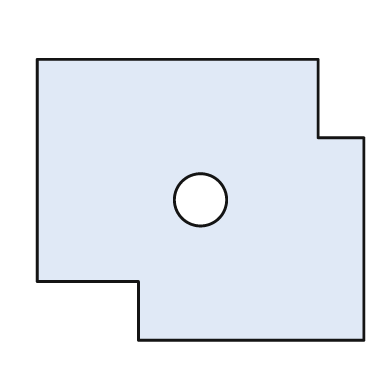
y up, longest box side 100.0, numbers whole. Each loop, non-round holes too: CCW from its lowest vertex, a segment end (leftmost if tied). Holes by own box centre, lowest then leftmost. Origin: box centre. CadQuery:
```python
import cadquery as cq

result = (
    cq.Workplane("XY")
    .moveTo(-19.0, -43.0)
    .lineTo(50.0, -43.0)
    .lineTo(50.0, 19.0)
    .lineTo(36.0, 19.0)
    .lineTo(36.0, 43.0)
    .lineTo(-50.0, 43.0)
    .lineTo(-50.0, -25.0)
    .lineTo(-19.0, -25.0)
    .close()
    .moveTo(0.0, 0.0)
    .circle(8.0)
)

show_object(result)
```